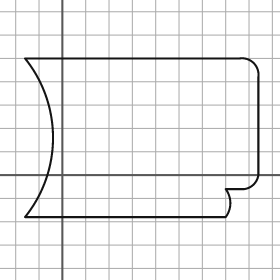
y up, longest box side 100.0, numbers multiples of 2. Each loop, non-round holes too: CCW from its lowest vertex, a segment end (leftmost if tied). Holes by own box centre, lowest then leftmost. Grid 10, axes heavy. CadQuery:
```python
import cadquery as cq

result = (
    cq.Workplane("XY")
    .moveTo(-16.0, -18.0)
    .lineTo(70.0, -18.0)
    .threePointArc((72.0, -12.0), (70.0, -6.0))
    .lineTo(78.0, -6.0)
    .threePointArc((82.0, -4.0), (84.0, 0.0))
    .lineTo(84.0, 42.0)
    .threePointArc((82.0, 48.0), (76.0, 50.0))
    .lineTo(-16.0, 50.0)
    .threePointArc((-4.0, 16.0), (-16.0, -18.0))
    .close()
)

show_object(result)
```